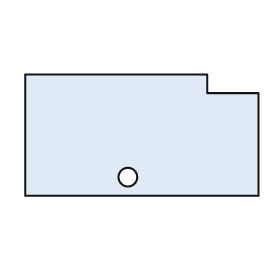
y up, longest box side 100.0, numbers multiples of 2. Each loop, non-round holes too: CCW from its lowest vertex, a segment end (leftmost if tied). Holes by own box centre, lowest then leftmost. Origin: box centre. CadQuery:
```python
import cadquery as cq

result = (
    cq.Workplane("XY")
    .moveTo(-50.0, -26.0)
    .lineTo(50.0, -26.0)
    .lineTo(50.0, 18.0)
    .lineTo(28.0, 18.0)
    .lineTo(28.0, 26.0)
    .lineTo(-50.0, 26.0)
    .close()
    .moveTo(-6.0, -18.0)
    .circle(4.0)
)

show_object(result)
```